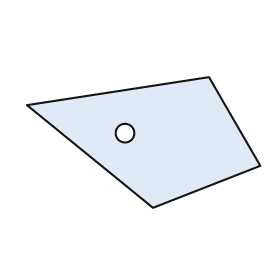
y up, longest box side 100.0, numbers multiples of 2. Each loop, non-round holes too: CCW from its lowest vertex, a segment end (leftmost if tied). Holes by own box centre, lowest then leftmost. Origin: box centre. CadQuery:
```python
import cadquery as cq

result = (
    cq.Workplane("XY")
    .moveTo(4.0, -28.0)
    .lineTo(50.0, -10.0)
    .lineTo(28.0, 28.0)
    .lineTo(-50.0, 16.0)
    .close()
    .moveTo(-8.0, 4.0)
    .circle(4.0)
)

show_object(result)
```